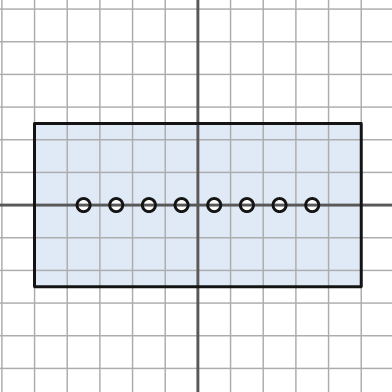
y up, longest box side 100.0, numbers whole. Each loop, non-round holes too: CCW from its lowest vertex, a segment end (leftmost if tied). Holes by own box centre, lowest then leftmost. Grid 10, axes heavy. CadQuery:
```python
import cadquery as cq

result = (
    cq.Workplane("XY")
    .moveTo(-50.0, -25.0)
    .lineTo(50.0, -25.0)
    .lineTo(50.0, 25.0)
    .lineTo(-50.0, 25.0)
    .close()
    .moveTo(-35.0, 0.0)
    .circle(2.0)
    .moveTo(-25.0, 0.0)
    .circle(2.0)
    .moveTo(-15.0, 0.0)
    .circle(2.0)
    .moveTo(-5.0, 0.0)
    .circle(2.0)
    .moveTo(5.0, 0.0)
    .circle(2.0)
    .moveTo(15.0, 0.0)
    .circle(2.0)
    .moveTo(25.0, 0.0)
    .circle(2.0)
    .moveTo(35.0, 0.0)
    .circle(2.0)
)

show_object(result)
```